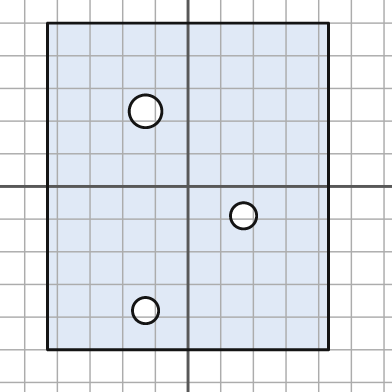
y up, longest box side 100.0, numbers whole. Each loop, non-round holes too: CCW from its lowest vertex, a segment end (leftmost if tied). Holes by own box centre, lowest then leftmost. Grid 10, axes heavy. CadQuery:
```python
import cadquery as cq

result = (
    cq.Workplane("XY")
    .moveTo(-43.0, -50.0)
    .lineTo(43.0, -50.0)
    .lineTo(43.0, 50.0)
    .lineTo(-43.0, 50.0)
    .close()
    .moveTo(-13.0, -38.0)
    .circle(4.0)
    .moveTo(17.0, -9.0)
    .circle(4.0)
    .moveTo(-13.0, 23.0)
    .circle(5.0)
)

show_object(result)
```